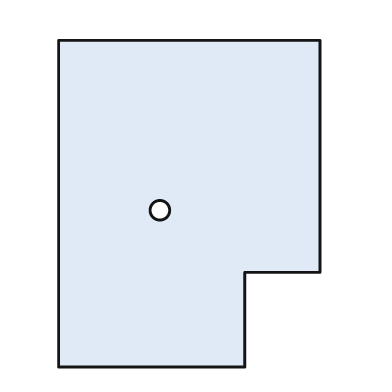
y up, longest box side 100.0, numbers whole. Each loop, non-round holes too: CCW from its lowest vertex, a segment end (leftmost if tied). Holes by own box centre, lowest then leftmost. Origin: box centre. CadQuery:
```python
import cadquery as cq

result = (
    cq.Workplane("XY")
    .moveTo(-40.0, -50.0)
    .lineTo(17.0, -50.0)
    .lineTo(17.0, -21.0)
    .lineTo(40.0, -21.0)
    .lineTo(40.0, 50.0)
    .lineTo(-40.0, 50.0)
    .close()
    .moveTo(-9.0, -2.0)
    .circle(3.0)
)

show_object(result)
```